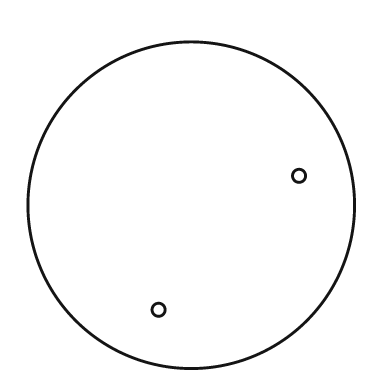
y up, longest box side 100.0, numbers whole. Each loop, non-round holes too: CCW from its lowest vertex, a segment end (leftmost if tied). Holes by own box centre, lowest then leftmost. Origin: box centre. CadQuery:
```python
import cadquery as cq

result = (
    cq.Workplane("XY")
    .moveTo(0.0, 0.0)
    .circle(50.0)
    .moveTo(-10.0, -32.0)
    .circle(2.0)
    .moveTo(33.0, 9.0)
    .circle(2.0)
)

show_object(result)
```